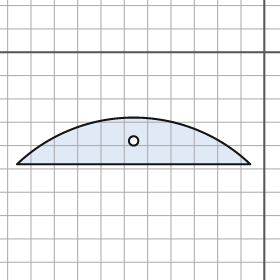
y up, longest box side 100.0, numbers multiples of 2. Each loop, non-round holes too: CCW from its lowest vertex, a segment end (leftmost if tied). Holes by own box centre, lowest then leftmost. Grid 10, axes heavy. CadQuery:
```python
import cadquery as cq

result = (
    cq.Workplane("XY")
    .moveTo(-106.0, -48.0)
    .lineTo(-6.0, -48.0)
    .threePointArc((-56.0, -28.0), (-106.0, -48.0))
    .close()
    .moveTo(-56.0, -38.0)
    .circle(2.0)
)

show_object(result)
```